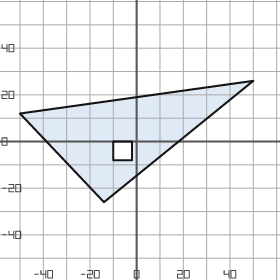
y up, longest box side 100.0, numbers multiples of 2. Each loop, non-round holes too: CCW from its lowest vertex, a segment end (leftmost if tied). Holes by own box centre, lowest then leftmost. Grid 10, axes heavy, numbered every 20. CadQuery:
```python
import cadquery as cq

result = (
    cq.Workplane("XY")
    .moveTo(-14.0, -26.0)
    .lineTo(50.0, 26.0)
    .lineTo(-50.0, 12.0)
    .close()
    .moveTo(-10.0, -8.0)
    .lineTo(-2.0, -8.0)
    .lineTo(-2.0, 0.0)
    .lineTo(-10.0, 0.0)
    .close()
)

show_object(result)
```